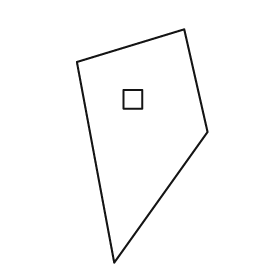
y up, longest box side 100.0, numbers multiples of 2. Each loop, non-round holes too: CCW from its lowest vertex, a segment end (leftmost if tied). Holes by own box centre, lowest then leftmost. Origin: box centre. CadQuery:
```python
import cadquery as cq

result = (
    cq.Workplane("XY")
    .moveTo(-12.0, -50.0)
    .lineTo(28.0, 6.0)
    .lineTo(18.0, 50.0)
    .lineTo(-28.0, 36.0)
    .close()
    .moveTo(-8.0, 16.0)
    .lineTo(0.0, 16.0)
    .lineTo(0.0, 24.0)
    .lineTo(-8.0, 24.0)
    .close()
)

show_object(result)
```